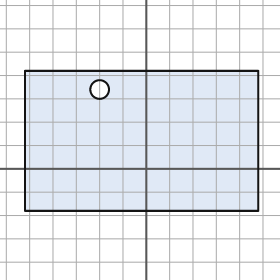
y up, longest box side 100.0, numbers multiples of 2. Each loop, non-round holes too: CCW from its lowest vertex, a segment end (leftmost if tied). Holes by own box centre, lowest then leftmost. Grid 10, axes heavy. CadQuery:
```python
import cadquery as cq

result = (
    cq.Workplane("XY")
    .moveTo(-52.0, -18.0)
    .lineTo(48.0, -18.0)
    .lineTo(48.0, 42.0)
    .lineTo(-52.0, 42.0)
    .close()
    .moveTo(-20.0, 34.0)
    .circle(4.0)
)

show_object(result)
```